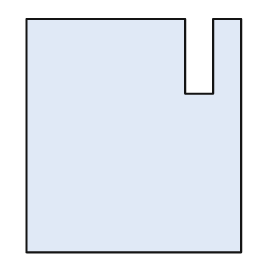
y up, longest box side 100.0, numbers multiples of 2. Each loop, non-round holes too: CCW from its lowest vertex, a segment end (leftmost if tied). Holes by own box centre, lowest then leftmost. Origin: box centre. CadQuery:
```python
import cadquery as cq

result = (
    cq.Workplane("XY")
    .moveTo(-46.0, -50.0)
    .lineTo(46.0, -50.0)
    .lineTo(46.0, 50.0)
    .lineTo(34.0, 50.0)
    .lineTo(34.0, 18.0)
    .lineTo(22.0, 18.0)
    .lineTo(22.0, 50.0)
    .lineTo(-46.0, 50.0)
    .close()
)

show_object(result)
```